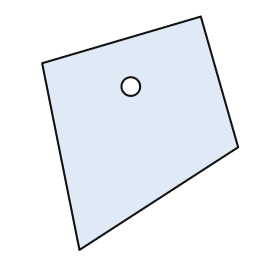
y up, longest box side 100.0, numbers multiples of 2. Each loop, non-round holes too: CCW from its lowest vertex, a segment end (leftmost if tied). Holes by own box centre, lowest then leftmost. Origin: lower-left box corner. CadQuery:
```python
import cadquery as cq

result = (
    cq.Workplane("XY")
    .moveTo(16.0, 0.0)
    .lineTo(84.0, 44.0)
    .lineTo(68.0, 100.0)
    .lineTo(0.0, 80.0)
    .close()
    .moveTo(38.0, 70.0)
    .circle(4.0)
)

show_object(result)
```